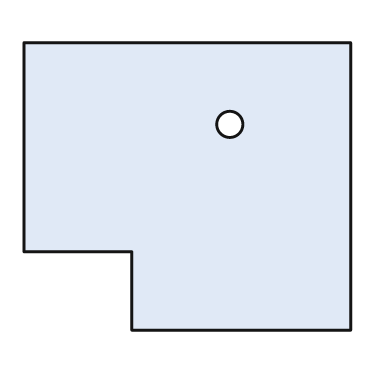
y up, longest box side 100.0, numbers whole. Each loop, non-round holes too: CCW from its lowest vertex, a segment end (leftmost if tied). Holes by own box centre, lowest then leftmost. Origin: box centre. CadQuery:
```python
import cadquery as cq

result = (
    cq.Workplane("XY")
    .moveTo(-17.0, -44.0)
    .lineTo(50.0, -44.0)
    .lineTo(50.0, 44.0)
    .lineTo(-50.0, 44.0)
    .lineTo(-50.0, -20.0)
    .lineTo(-17.0, -20.0)
    .close()
    .moveTo(13.0, 19.0)
    .circle(4.0)
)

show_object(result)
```